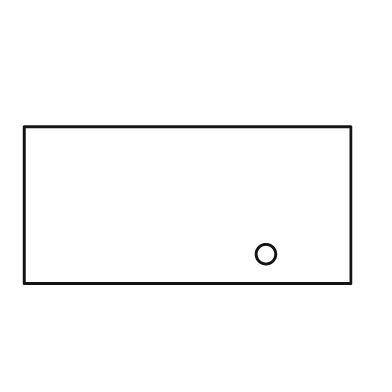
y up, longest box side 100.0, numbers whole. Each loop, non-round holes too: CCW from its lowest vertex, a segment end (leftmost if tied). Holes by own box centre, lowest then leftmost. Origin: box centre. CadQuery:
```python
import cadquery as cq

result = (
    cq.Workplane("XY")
    .moveTo(-50.0, -24.0)
    .lineTo(50.0, -24.0)
    .lineTo(50.0, 24.0)
    .lineTo(-50.0, 24.0)
    .close()
    .moveTo(24.0, -15.0)
    .circle(3.0)
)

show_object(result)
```